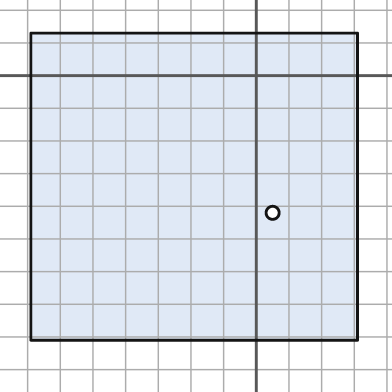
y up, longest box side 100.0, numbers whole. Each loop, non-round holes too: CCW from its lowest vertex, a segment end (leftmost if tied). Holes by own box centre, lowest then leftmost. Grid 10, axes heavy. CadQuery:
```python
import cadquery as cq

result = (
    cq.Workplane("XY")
    .moveTo(-69.0, -81.0)
    .lineTo(31.0, -81.0)
    .lineTo(31.0, 13.0)
    .lineTo(-69.0, 13.0)
    .close()
    .moveTo(5.0, -42.0)
    .circle(2.0)
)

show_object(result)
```